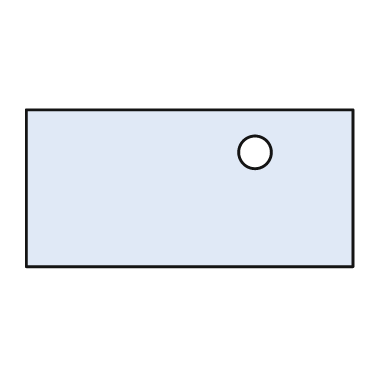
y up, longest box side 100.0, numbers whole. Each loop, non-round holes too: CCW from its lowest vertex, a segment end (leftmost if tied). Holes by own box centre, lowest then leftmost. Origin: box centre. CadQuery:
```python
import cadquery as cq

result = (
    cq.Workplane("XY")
    .moveTo(-50.0, -24.0)
    .lineTo(50.0, -24.0)
    .lineTo(50.0, 24.0)
    .lineTo(-50.0, 24.0)
    .close()
    .moveTo(20.0, 11.0)
    .circle(5.0)
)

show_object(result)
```